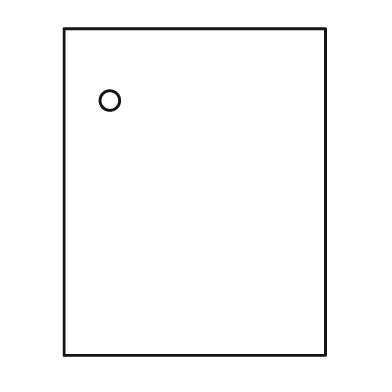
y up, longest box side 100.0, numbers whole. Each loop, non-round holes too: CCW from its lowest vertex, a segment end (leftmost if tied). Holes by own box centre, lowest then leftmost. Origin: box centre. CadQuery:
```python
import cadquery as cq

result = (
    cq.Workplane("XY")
    .moveTo(-40.0, -50.0)
    .lineTo(40.0, -50.0)
    .lineTo(40.0, 50.0)
    .lineTo(-40.0, 50.0)
    .close()
    .moveTo(-26.0, 28.0)
    .circle(3.0)
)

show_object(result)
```